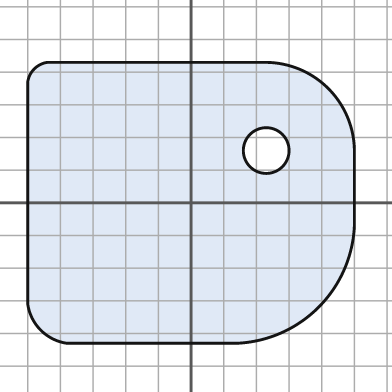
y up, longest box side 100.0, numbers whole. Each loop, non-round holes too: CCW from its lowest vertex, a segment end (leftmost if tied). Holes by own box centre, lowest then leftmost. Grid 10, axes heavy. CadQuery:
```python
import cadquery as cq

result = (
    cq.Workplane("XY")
    .moveTo(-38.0, -43.0)
    .lineTo(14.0, -43.0)
    .threePointArc((39.0, -32.0), (50.0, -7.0))
    .lineTo(50.0, 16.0)
    .threePointArc((42.0, 35.0), (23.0, 43.0))
    .lineTo(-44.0, 43.0)
    .threePointArc((-48.0, 41.0), (-50.0, 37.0))
    .lineTo(-50.0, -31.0)
    .threePointArc((-46.0, -39.0), (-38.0, -43.0))
    .close()
    .moveTo(23.0, 16.0)
    .circle(7.0)
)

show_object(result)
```